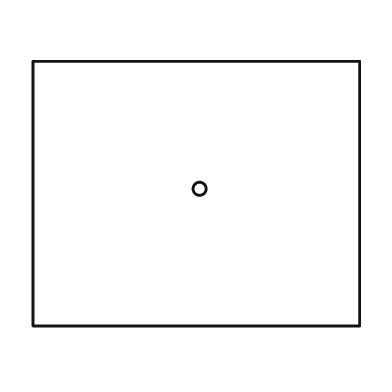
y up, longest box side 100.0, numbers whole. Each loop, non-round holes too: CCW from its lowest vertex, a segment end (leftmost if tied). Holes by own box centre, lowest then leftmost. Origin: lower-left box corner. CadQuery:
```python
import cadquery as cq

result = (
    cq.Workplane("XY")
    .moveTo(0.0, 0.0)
    .lineTo(100.0, 0.0)
    .lineTo(100.0, 81.0)
    .lineTo(0.0, 81.0)
    .close()
    .moveTo(51.0, 42.0)
    .circle(2.0)
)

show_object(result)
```